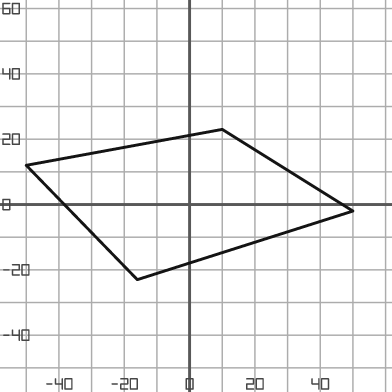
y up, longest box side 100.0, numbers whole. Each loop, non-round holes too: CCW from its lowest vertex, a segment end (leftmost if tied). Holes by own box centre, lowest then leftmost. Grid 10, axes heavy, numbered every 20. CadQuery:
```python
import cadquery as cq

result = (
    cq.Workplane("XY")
    .moveTo(-16.0, -23.0)
    .lineTo(50.0, -2.0)
    .lineTo(10.0, 23.0)
    .lineTo(-50.0, 12.0)
    .close()
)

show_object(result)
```